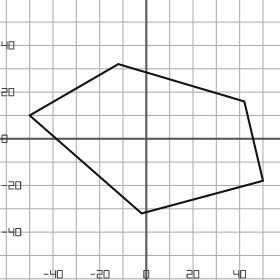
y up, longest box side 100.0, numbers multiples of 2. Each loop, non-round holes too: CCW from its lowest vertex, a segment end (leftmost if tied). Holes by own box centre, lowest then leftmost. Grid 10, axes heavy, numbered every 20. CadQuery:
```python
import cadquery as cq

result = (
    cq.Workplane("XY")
    .moveTo(-2.0, -32.0)
    .lineTo(50.0, -18.0)
    .lineTo(42.0, 16.0)
    .lineTo(-12.0, 32.0)
    .lineTo(-50.0, 10.0)
    .close()
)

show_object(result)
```